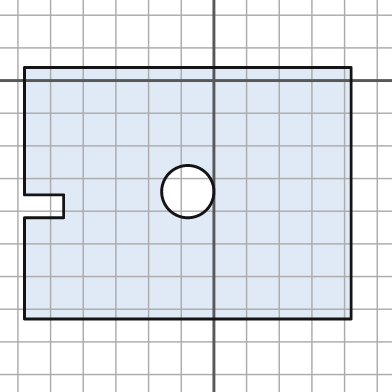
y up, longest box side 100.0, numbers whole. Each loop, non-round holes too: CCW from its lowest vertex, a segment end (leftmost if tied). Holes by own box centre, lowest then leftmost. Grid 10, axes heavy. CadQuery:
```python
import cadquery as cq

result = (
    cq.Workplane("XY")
    .moveTo(-58.0, -73.0)
    .lineTo(42.0, -73.0)
    .lineTo(42.0, 4.0)
    .lineTo(-58.0, 4.0)
    .lineTo(-58.0, -35.0)
    .lineTo(-46.0, -35.0)
    .lineTo(-46.0, -42.0)
    .lineTo(-58.0, -42.0)
    .close()
    .moveTo(-8.0, -34.0)
    .circle(8.0)
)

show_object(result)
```